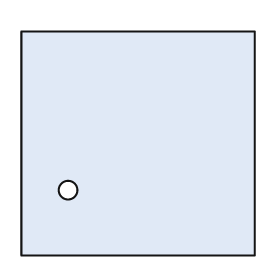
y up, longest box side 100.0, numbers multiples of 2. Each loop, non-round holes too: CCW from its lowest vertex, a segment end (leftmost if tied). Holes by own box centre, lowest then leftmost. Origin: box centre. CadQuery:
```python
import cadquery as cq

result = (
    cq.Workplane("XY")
    .moveTo(-50.0, -48.0)
    .lineTo(50.0, -48.0)
    .lineTo(50.0, 48.0)
    .lineTo(-50.0, 48.0)
    .close()
    .moveTo(-30.0, -20.0)
    .circle(4.0)
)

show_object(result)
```